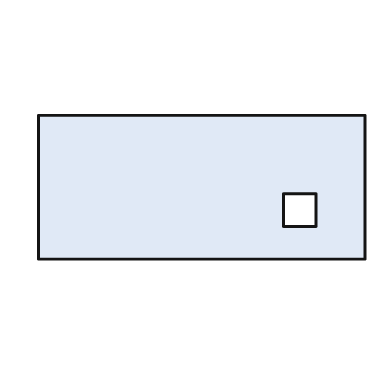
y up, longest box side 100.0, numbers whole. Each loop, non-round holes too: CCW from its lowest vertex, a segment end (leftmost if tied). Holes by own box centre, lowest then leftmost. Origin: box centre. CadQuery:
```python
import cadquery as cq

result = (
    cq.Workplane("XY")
    .moveTo(-50.0, -22.0)
    .lineTo(50.0, -22.0)
    .lineTo(50.0, 22.0)
    .lineTo(-50.0, 22.0)
    .close()
    .moveTo(25.0, -12.0)
    .lineTo(35.0, -12.0)
    .lineTo(35.0, -2.0)
    .lineTo(25.0, -2.0)
    .close()
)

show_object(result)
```